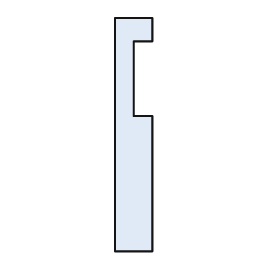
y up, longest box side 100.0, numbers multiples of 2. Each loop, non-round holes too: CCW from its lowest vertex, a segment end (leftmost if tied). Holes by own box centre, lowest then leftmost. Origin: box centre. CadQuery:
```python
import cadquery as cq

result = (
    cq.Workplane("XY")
    .moveTo(-8.0, -50.0)
    .lineTo(8.0, -50.0)
    .lineTo(8.0, 8.0)
    .lineTo(0.0, 8.0)
    .lineTo(0.0, 40.0)
    .lineTo(8.0, 40.0)
    .lineTo(8.0, 50.0)
    .lineTo(-8.0, 50.0)
    .close()
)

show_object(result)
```